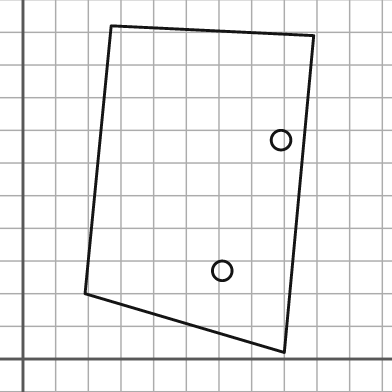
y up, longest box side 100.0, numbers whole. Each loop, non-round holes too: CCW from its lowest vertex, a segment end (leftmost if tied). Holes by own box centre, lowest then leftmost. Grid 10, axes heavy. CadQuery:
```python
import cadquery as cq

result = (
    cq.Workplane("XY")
    .moveTo(80.0, 2.0)
    .lineTo(89.0, 99.0)
    .lineTo(27.0, 102.0)
    .lineTo(19.0, 20.0)
    .close()
    .moveTo(61.0, 27.0)
    .circle(3.0)
    .moveTo(79.0, 67.0)
    .circle(3.0)
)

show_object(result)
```